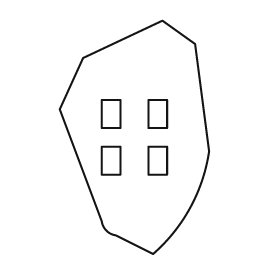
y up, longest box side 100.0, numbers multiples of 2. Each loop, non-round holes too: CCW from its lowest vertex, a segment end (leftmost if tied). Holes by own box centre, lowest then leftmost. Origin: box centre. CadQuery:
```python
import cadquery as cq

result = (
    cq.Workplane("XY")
    .moveTo(8.0, -50.0)
    .threePointArc((24.0, -30.0), (32.0, -6.0))
    .lineTo(26.0, 40.0)
    .lineTo(12.0, 50.0)
    .lineTo(-22.0, 34.0)
    .lineTo(-32.0, 12.0)
    .lineTo(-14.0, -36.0)
    .threePointArc((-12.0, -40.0), (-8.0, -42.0))
    .close()
    .moveTo(-14.0, -16.0)
    .lineTo(-6.0, -16.0)
    .lineTo(-6.0, -4.0)
    .lineTo(-14.0, -4.0)
    .close()
    .moveTo(6.0, -16.0)
    .lineTo(14.0, -16.0)
    .lineTo(14.0, -4.0)
    .lineTo(6.0, -4.0)
    .close()
    .moveTo(-14.0, 4.0)
    .lineTo(-6.0, 4.0)
    .lineTo(-6.0, 16.0)
    .lineTo(-14.0, 16.0)
    .close()
    .moveTo(6.0, 4.0)
    .lineTo(14.0, 4.0)
    .lineTo(14.0, 16.0)
    .lineTo(6.0, 16.0)
    .close()
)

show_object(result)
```